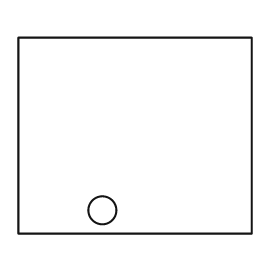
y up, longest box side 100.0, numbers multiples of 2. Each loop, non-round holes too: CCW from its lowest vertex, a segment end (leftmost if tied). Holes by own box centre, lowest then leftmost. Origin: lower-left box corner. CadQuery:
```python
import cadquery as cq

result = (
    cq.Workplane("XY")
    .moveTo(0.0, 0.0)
    .lineTo(100.0, 0.0)
    .lineTo(100.0, 84.0)
    .lineTo(0.0, 84.0)
    .close()
    .moveTo(36.0, 10.0)
    .circle(6.0)
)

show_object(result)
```